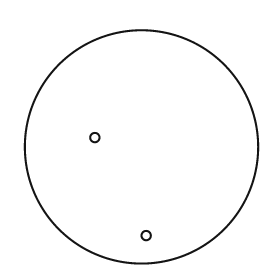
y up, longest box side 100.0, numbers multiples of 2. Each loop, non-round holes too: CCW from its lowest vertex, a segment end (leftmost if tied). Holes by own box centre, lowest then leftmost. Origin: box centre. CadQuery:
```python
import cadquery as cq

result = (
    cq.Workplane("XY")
    .moveTo(0.0, 0.0)
    .circle(50.0)
    .moveTo(2.0, -38.0)
    .circle(2.0)
    .moveTo(-20.0, 4.0)
    .circle(2.0)
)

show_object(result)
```